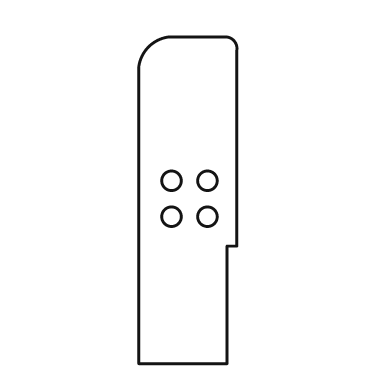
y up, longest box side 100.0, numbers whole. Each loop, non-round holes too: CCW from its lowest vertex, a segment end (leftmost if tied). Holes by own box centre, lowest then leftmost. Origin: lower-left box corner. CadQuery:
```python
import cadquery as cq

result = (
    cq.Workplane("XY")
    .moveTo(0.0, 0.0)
    .lineTo(27.0, 0.0)
    .lineTo(27.0, 36.0)
    .lineTo(30.0, 36.0)
    .lineTo(30.0, 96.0)
    .threePointArc((29.0, 99.0), (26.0, 100.0))
    .lineTo(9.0, 100.0)
    .threePointArc((3.0, 97.0), (0.0, 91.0))
    .close()
    .moveTo(10.0, 45.0)
    .circle(3.0)
    .moveTo(21.0, 45.0)
    .circle(3.0)
    .moveTo(10.0, 56.0)
    .circle(3.0)
    .moveTo(21.0, 56.0)
    .circle(3.0)
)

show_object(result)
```